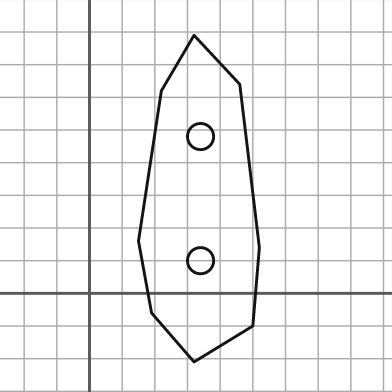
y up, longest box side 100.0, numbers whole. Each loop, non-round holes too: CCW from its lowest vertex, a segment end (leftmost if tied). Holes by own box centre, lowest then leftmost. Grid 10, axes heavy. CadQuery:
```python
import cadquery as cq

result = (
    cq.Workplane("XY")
    .moveTo(32.0, -21.0)
    .lineTo(50.0, -10.0)
    .lineTo(52.0, 14.0)
    .lineTo(46.0, 64.0)
    .lineTo(32.0, 79.0)
    .lineTo(22.0, 62.0)
    .lineTo(15.0, 16.0)
    .lineTo(19.0, -6.0)
    .close()
    .moveTo(34.0, 10.0)
    .circle(4.0)
    .moveTo(34.0, 48.0)
    .circle(4.0)
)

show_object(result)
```